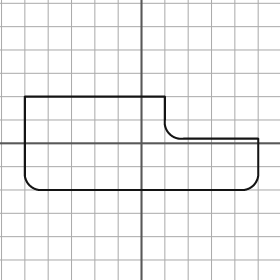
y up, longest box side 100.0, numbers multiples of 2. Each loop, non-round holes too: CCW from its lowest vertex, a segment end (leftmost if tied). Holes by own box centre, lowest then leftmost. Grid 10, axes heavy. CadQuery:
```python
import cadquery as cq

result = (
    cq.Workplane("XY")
    .moveTo(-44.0, -20.0)
    .lineTo(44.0, -20.0)
    .threePointArc((48.0, -18.0), (50.0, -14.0))
    .lineTo(50.0, 2.0)
    .lineTo(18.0, 2.0)
    .threePointArc((12.0, 4.0), (10.0, 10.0))
    .lineTo(10.0, 20.0)
    .lineTo(-50.0, 20.0)
    .lineTo(-50.0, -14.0)
    .threePointArc((-48.0, -18.0), (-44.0, -20.0))
    .close()
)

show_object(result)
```